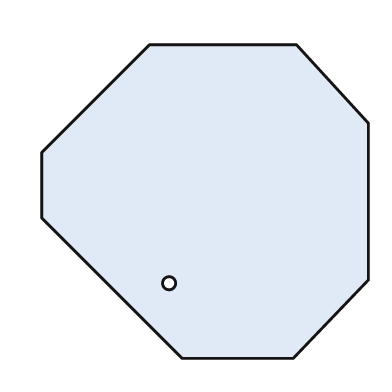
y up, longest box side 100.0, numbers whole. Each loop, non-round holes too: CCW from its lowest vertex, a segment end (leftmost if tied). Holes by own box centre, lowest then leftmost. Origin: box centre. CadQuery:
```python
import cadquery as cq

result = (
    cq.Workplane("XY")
    .moveTo(-7.0, -48.0)
    .lineTo(27.0, -48.0)
    .lineTo(50.0, -24.0)
    .lineTo(50.0, 24.0)
    .lineTo(28.0, 48.0)
    .lineTo(-17.0, 48.0)
    .lineTo(-50.0, 15.0)
    .lineTo(-50.0, -5.0)
    .close()
    .moveTo(-11.0, -25.0)
    .circle(2.0)
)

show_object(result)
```